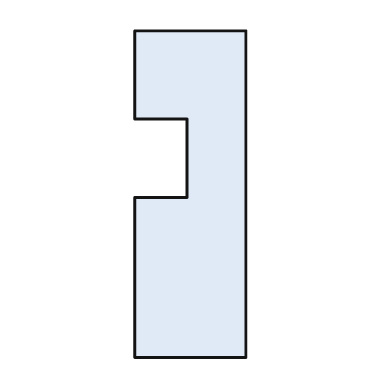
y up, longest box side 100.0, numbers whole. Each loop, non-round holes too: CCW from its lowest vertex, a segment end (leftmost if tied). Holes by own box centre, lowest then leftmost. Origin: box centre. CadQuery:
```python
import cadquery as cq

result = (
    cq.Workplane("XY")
    .moveTo(-17.0, -50.0)
    .lineTo(17.0, -50.0)
    .lineTo(17.0, 50.0)
    .lineTo(-17.0, 50.0)
    .lineTo(-17.0, 23.0)
    .lineTo(-1.0, 23.0)
    .lineTo(-1.0, -1.0)
    .lineTo(-17.0, -1.0)
    .close()
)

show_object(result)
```